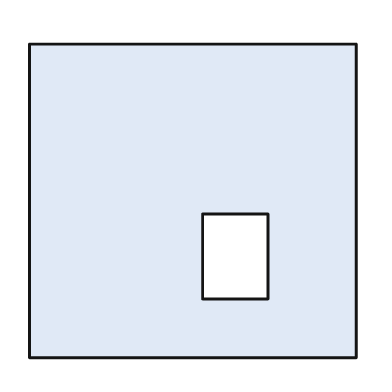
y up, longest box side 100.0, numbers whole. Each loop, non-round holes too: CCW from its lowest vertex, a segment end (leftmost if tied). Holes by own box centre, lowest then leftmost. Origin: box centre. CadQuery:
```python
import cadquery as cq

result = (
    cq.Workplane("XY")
    .moveTo(-50.0, -48.0)
    .lineTo(50.0, -48.0)
    .lineTo(50.0, 48.0)
    .lineTo(-50.0, 48.0)
    .close()
    .moveTo(3.0, -30.0)
    .lineTo(23.0, -30.0)
    .lineTo(23.0, -4.0)
    .lineTo(3.0, -4.0)
    .close()
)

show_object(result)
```